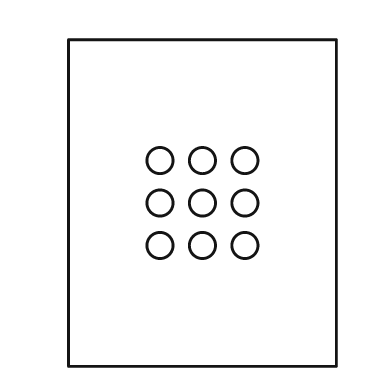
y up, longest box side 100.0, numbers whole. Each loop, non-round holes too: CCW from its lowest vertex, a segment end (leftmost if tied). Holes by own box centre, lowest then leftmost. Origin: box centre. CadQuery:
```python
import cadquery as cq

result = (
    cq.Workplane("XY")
    .moveTo(-41.0, -50.0)
    .lineTo(41.0, -50.0)
    .lineTo(41.0, 50.0)
    .lineTo(-41.0, 50.0)
    .close()
    .moveTo(-13.0, -13.0)
    .circle(4.0)
    .moveTo(0.0, -13.0)
    .circle(4.0)
    .moveTo(13.0, -13.0)
    .circle(4.0)
    .moveTo(-13.0, 0.0)
    .circle(4.0)
    .moveTo(0.0, 0.0)
    .circle(4.0)
    .moveTo(13.0, 0.0)
    .circle(4.0)
    .moveTo(-13.0, 13.0)
    .circle(4.0)
    .moveTo(0.0, 13.0)
    .circle(4.0)
    .moveTo(13.0, 13.0)
    .circle(4.0)
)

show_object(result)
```